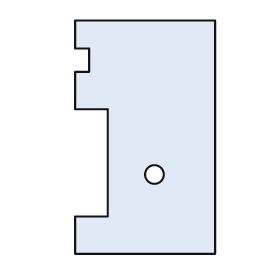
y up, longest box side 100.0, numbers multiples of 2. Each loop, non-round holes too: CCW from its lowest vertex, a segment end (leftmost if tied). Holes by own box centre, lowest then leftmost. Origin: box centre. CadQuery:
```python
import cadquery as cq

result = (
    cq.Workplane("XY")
    .moveTo(-30.0, -50.0)
    .lineTo(30.0, -50.0)
    .lineTo(30.0, 50.0)
    .lineTo(-30.0, 50.0)
    .lineTo(-30.0, 38.0)
    .lineTo(-24.0, 38.0)
    .lineTo(-24.0, 28.0)
    .lineTo(-30.0, 28.0)
    .lineTo(-30.0, 12.0)
    .lineTo(-16.0, 12.0)
    .lineTo(-16.0, -34.0)
    .lineTo(-30.0, -34.0)
    .close()
    .moveTo(4.0, -16.0)
    .circle(4.0)
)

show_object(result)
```